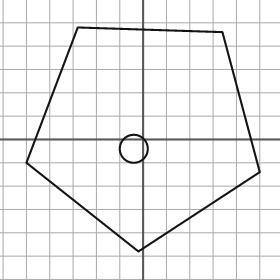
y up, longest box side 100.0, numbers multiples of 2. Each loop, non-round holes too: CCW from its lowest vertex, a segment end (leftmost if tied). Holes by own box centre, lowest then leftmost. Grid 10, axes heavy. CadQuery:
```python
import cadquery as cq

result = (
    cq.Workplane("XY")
    .moveTo(-2.0, -48.0)
    .lineTo(50.0, -14.0)
    .lineTo(34.0, 46.0)
    .lineTo(-28.0, 48.0)
    .lineTo(-50.0, -10.0)
    .close()
    .moveTo(-4.0, -4.0)
    .circle(6.0)
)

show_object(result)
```